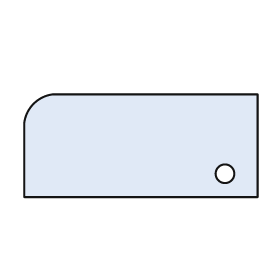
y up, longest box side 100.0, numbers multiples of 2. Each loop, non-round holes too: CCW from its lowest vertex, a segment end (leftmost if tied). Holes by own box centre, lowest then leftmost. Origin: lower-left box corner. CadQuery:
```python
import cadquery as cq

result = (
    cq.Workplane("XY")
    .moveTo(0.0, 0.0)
    .lineTo(100.0, 0.0)
    .lineTo(100.0, 44.0)
    .lineTo(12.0, 44.0)
    .threePointArc((4.0, 40.0), (0.0, 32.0))
    .close()
    .moveTo(86.0, 10.0)
    .circle(4.0)
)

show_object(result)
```